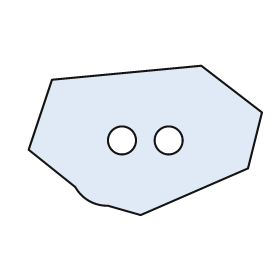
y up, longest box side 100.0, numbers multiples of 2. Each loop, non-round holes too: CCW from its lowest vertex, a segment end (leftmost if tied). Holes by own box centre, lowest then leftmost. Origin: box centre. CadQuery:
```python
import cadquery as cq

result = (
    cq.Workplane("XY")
    .moveTo(-2.0, -32.0)
    .lineTo(44.0, -12.0)
    .lineTo(50.0, 12.0)
    .lineTo(24.0, 32.0)
    .lineTo(-40.0, 26.0)
    .lineTo(-50.0, -4.0)
    .lineTo(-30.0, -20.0)
    .threePointArc((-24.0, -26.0), (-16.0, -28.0))
    .close()
    .moveTo(-10.0, 0.0)
    .circle(6.0)
    .moveTo(10.0, 0.0)
    .circle(6.0)
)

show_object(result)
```